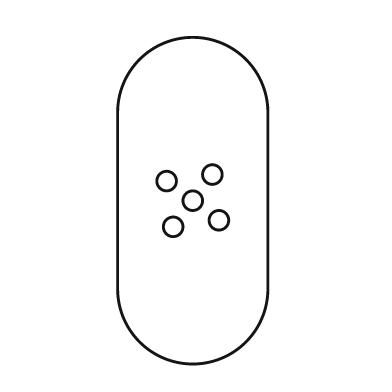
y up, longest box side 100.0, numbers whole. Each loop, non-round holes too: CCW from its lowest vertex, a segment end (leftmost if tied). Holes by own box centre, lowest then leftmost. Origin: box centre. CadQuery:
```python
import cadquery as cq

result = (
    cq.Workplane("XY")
    .moveTo(-23.0, -27.0)
    .threePointArc((0.0, -50.0), (23.0, -27.0))
    .lineTo(23.0, 27.0)
    .threePointArc((0.0, 50.0), (-23.0, 27.0))
    .close()
    .moveTo(-6.0, -8.0)
    .circle(3.0)
    .moveTo(8.0, -6.0)
    .circle(3.0)
    .moveTo(0.0, 0.0)
    .circle(3.0)
    .moveTo(-8.0, 6.0)
    .circle(3.0)
    .moveTo(6.0, 8.0)
    .circle(3.0)
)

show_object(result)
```